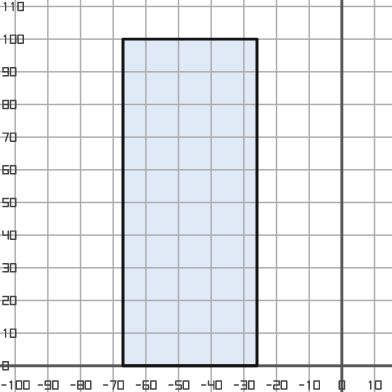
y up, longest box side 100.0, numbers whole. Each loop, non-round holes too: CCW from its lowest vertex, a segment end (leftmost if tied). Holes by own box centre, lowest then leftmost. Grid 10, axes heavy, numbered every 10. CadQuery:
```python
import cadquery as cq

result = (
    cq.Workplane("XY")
    .moveTo(-67.0, 0.0)
    .lineTo(-26.0, 0.0)
    .lineTo(-26.0, 100.0)
    .lineTo(-67.0, 100.0)
    .close()
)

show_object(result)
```